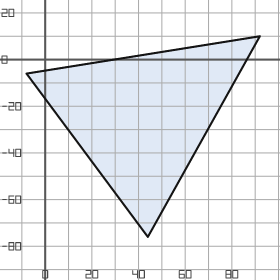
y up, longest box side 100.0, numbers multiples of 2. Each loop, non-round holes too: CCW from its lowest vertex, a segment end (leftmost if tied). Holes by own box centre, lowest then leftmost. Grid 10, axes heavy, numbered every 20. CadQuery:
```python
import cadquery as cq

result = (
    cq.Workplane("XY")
    .moveTo(44.0, -76.0)
    .lineTo(92.0, 10.0)
    .lineTo(-8.0, -6.0)
    .close()
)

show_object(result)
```